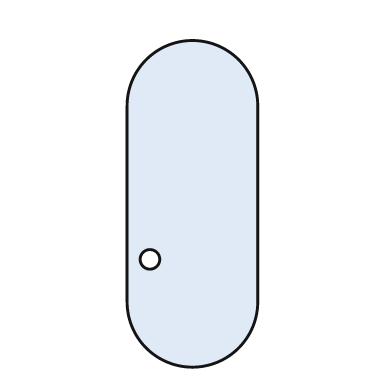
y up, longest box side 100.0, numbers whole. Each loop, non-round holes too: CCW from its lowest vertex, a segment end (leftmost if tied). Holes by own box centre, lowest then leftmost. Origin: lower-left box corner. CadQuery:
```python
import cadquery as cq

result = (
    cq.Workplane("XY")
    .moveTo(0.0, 20.0)
    .threePointArc((20.0, 0.0), (40.0, 20.0))
    .lineTo(40.0, 80.0)
    .threePointArc((20.0, 100.0), (0.0, 80.0))
    .close()
    .moveTo(7.0, 33.0)
    .circle(3.0)
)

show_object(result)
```